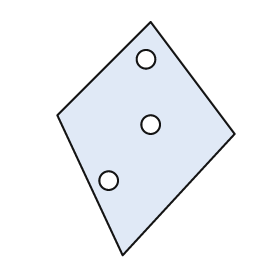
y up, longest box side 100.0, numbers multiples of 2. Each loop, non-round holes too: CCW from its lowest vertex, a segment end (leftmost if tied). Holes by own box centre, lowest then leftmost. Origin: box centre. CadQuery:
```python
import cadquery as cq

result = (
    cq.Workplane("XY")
    .moveTo(-10.0, -50.0)
    .lineTo(38.0, 2.0)
    .lineTo(2.0, 50.0)
    .lineTo(-38.0, 10.0)
    .close()
    .moveTo(-16.0, -18.0)
    .circle(4.0)
    .moveTo(2.0, 6.0)
    .circle(4.0)
    .moveTo(0.0, 34.0)
    .circle(4.0)
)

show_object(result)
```